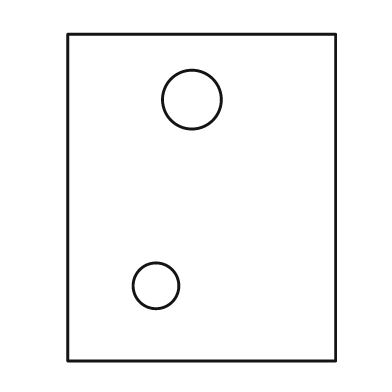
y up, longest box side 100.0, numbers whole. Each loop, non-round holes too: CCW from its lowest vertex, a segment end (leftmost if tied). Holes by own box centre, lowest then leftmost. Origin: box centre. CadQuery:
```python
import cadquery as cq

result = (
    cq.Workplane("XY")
    .moveTo(-41.0, -50.0)
    .lineTo(41.0, -50.0)
    .lineTo(41.0, 50.0)
    .lineTo(-41.0, 50.0)
    .close()
    .moveTo(-14.0, -27.0)
    .circle(7.0)
    .moveTo(-3.0, 30.0)
    .circle(9.0)
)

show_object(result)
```